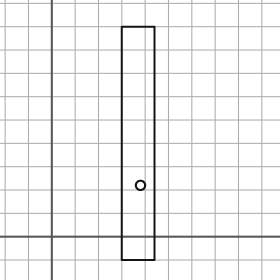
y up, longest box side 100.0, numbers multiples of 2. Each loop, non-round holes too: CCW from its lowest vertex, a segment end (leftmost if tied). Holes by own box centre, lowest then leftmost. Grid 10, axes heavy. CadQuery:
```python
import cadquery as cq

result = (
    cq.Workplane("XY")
    .moveTo(30.0, -10.0)
    .lineTo(44.0, -10.0)
    .lineTo(44.0, 90.0)
    .lineTo(30.0, 90.0)
    .close()
    .moveTo(38.0, 22.0)
    .circle(2.0)
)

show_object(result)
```